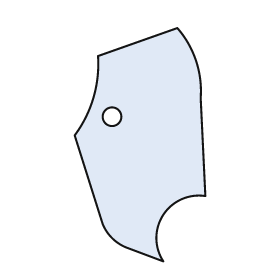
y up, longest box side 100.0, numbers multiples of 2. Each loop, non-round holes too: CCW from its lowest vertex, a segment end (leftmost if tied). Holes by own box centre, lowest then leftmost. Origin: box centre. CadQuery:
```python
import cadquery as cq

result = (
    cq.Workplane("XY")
    .moveTo(10.0, -50.0)
    .threePointArc((10.0, -30.0), (28.0, -22.0))
    .lineTo(26.0, 20.0)
    .threePointArc((24.0, 36.0), (16.0, 50.0))
    .lineTo(-18.0, 38.0)
    .threePointArc((-20.0, 20.0), (-28.0, 4.0))
    .lineTo(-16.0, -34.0)
    .threePointArc((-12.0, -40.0), (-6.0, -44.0))
    .close()
    .moveTo(-12.0, 12.0)
    .circle(4.0)
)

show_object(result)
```